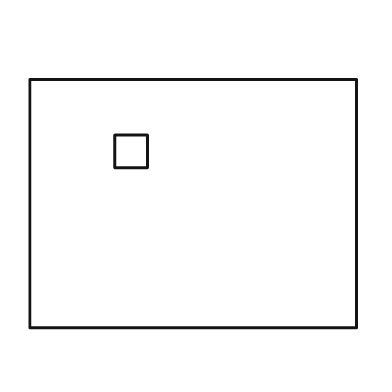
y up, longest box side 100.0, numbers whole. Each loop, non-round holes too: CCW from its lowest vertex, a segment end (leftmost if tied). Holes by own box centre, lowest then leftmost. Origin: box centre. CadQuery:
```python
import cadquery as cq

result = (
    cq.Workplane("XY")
    .moveTo(-50.0, -38.0)
    .lineTo(50.0, -38.0)
    .lineTo(50.0, 38.0)
    .lineTo(-50.0, 38.0)
    .close()
    .moveTo(-24.0, 11.0)
    .lineTo(-14.0, 11.0)
    .lineTo(-14.0, 21.0)
    .lineTo(-24.0, 21.0)
    .close()
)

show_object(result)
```